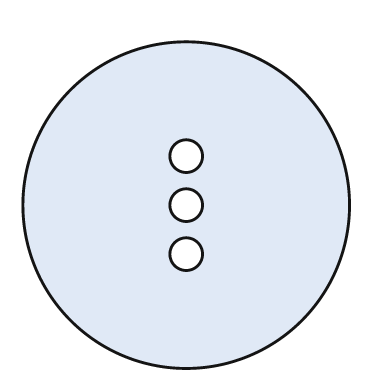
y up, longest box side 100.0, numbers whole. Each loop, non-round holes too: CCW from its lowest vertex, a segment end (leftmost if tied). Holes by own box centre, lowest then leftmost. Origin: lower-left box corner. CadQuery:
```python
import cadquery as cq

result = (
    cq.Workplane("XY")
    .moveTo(50.0, 50.0)
    .circle(50.0)
    .moveTo(50.0, 35.0)
    .circle(5.0)
    .moveTo(50.0, 50.0)
    .circle(5.0)
    .moveTo(50.0, 65.0)
    .circle(5.0)
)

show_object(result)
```